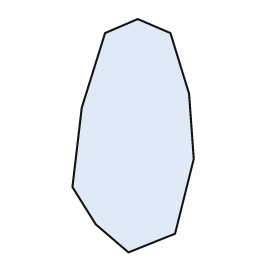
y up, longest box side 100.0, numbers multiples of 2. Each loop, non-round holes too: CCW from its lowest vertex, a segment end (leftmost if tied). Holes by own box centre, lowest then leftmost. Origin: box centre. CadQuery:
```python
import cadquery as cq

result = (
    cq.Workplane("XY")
    .moveTo(-2.0, -50.0)
    .lineTo(18.0, -42.0)
    .lineTo(26.0, -10.0)
    .lineTo(24.0, 18.0)
    .lineTo(16.0, 44.0)
    .lineTo(2.0, 50.0)
    .lineTo(-12.0, 44.0)
    .lineTo(-22.0, 12.0)
    .lineTo(-26.0, -22.0)
    .lineTo(-16.0, -38.0)
    .close()
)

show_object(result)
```